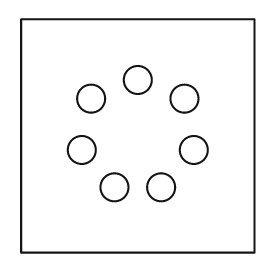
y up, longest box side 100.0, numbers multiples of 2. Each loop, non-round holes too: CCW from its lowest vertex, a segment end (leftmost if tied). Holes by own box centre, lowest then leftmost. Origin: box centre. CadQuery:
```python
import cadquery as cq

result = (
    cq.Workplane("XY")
    .moveTo(-50.0, -50.0)
    .lineTo(50.0, -50.0)
    .lineTo(50.0, 50.0)
    .lineTo(-50.0, 50.0)
    .close()
    .moveTo(-10.0, -22.0)
    .circle(6.0)
    .moveTo(10.0, -22.0)
    .circle(6.0)
    .moveTo(-24.0, -6.0)
    .circle(6.0)
    .moveTo(24.0, -6.0)
    .circle(6.0)
    .moveTo(-20.0, 16.0)
    .circle(6.0)
    .moveTo(20.0, 16.0)
    .circle(6.0)
    .moveTo(0.0, 24.0)
    .circle(6.0)
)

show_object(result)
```